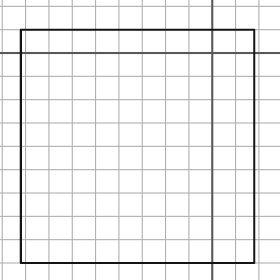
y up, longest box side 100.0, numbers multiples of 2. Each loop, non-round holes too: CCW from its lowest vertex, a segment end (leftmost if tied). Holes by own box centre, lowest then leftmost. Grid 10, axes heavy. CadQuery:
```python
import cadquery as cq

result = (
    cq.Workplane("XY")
    .moveTo(-82.0, -90.0)
    .lineTo(18.0, -90.0)
    .lineTo(18.0, 10.0)
    .lineTo(-82.0, 10.0)
    .close()
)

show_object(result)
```